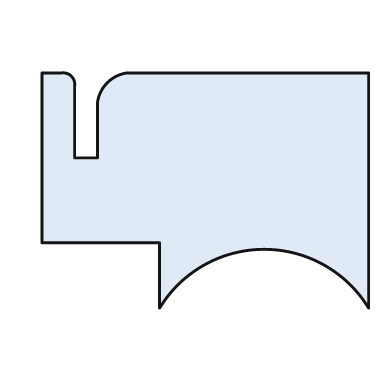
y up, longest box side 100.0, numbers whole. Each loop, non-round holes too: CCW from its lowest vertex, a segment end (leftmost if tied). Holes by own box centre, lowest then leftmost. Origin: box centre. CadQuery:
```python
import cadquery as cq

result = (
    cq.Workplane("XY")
    .moveTo(-14.0, -36.0)
    .threePointArc((18.0, -18.0), (50.0, -36.0))
    .lineTo(50.0, 36.0)
    .lineTo(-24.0, 36.0)
    .threePointArc((-30.0, 33.0), (-33.0, 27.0))
    .lineTo(-33.0, 10.0)
    .lineTo(-40.0, 10.0)
    .lineTo(-40.0, 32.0)
    .threePointArc((-41.0, 35.0), (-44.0, 36.0))
    .lineTo(-50.0, 36.0)
    .lineTo(-50.0, -16.0)
    .lineTo(-14.0, -16.0)
    .close()
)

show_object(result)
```